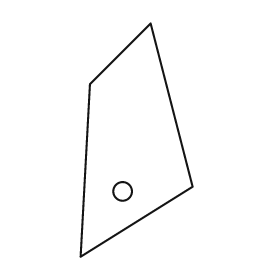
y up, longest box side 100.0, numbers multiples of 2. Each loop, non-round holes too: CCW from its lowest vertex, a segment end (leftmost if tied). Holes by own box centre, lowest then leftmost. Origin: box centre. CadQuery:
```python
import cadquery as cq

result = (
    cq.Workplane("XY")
    .moveTo(-24.0, -50.0)
    .lineTo(24.0, -20.0)
    .lineTo(6.0, 50.0)
    .lineTo(-20.0, 24.0)
    .close()
    .moveTo(-6.0, -22.0)
    .circle(4.0)
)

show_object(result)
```